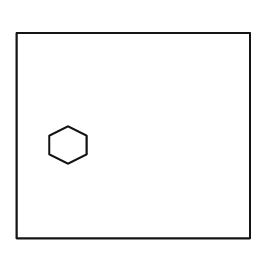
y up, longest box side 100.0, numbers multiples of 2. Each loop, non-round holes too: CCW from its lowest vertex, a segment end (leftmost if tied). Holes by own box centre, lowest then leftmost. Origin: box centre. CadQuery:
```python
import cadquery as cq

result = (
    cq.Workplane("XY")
    .moveTo(-50.0, -44.0)
    .lineTo(50.0, -44.0)
    .lineTo(50.0, 44.0)
    .lineTo(-50.0, 44.0)
    .close()
    .moveTo(-28.0, -12.0)
    .lineTo(-20.0, -8.0)
    .lineTo(-20.0, 0.0)
    .lineTo(-28.0, 4.0)
    .lineTo(-36.0, 0.0)
    .lineTo(-36.0, -8.0)
    .close()
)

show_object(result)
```